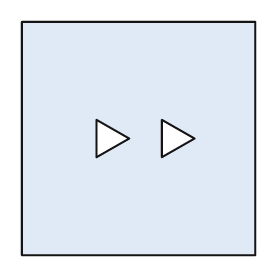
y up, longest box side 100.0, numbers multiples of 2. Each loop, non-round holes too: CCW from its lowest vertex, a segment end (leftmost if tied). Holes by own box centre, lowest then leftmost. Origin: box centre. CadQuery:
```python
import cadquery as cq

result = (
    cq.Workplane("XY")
    .moveTo(-50.0, -50.0)
    .lineTo(50.0, -50.0)
    .lineTo(50.0, 50.0)
    .lineTo(-50.0, 50.0)
    .close()
    .moveTo(-18.0, -8.0)
    .lineTo(-4.0, 0.0)
    .lineTo(-18.0, 8.0)
    .close()
    .moveTo(10.0, -8.0)
    .lineTo(24.0, 0.0)
    .lineTo(10.0, 8.0)
    .close()
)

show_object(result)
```